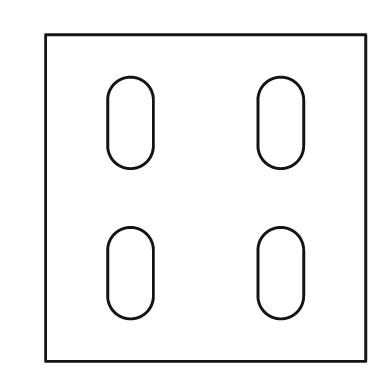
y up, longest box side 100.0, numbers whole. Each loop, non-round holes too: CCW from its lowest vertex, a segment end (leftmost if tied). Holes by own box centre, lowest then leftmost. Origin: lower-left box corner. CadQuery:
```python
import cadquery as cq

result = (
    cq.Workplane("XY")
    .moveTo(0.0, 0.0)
    .lineTo(98.0, 0.0)
    .lineTo(98.0, 100.0)
    .lineTo(0.0, 100.0)
    .close()
    .moveTo(19.0, 20.0)
    .threePointArc((26.0, 13.0), (33.0, 20.0))
    .lineTo(33.0, 34.0)
    .threePointArc((26.0, 41.0), (19.0, 34.0))
    .close()
    .moveTo(65.0, 20.0)
    .threePointArc((72.0, 13.0), (79.0, 20.0))
    .lineTo(79.0, 34.0)
    .threePointArc((72.0, 41.0), (65.0, 34.0))
    .close()
    .moveTo(19.0, 66.0)
    .threePointArc((26.0, 59.0), (33.0, 66.0))
    .lineTo(33.0, 80.0)
    .threePointArc((26.0, 87.0), (19.0, 80.0))
    .close()
    .moveTo(65.0, 66.0)
    .threePointArc((72.0, 59.0), (79.0, 66.0))
    .lineTo(79.0, 80.0)
    .threePointArc((72.0, 87.0), (65.0, 80.0))
    .close()
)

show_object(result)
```